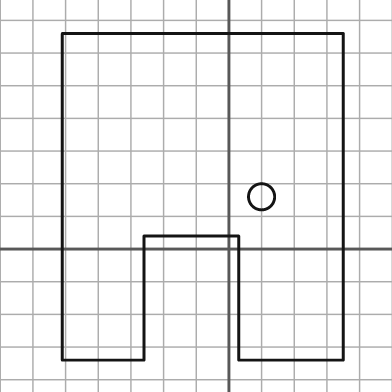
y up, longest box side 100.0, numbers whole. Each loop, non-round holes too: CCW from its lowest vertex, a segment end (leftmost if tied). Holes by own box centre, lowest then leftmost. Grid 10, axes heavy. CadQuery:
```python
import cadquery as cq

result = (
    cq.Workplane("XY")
    .moveTo(-51.0, -34.0)
    .lineTo(-26.0, -34.0)
    .lineTo(-26.0, 4.0)
    .lineTo(3.0, 4.0)
    .lineTo(3.0, -34.0)
    .lineTo(35.0, -34.0)
    .lineTo(35.0, 66.0)
    .lineTo(-51.0, 66.0)
    .close()
    .moveTo(10.0, 16.0)
    .circle(4.0)
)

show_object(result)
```